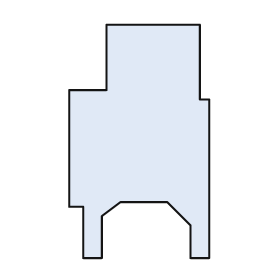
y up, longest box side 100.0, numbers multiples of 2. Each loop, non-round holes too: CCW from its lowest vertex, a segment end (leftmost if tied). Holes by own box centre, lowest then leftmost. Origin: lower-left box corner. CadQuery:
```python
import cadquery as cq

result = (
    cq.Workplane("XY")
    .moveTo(6.0, 0.0)
    .lineTo(14.0, 0.0)
    .lineTo(14.0, 18.0)
    .lineTo(22.0, 24.0)
    .lineTo(42.0, 24.0)
    .lineTo(52.0, 14.0)
    .lineTo(52.0, 0.0)
    .lineTo(60.0, 0.0)
    .lineTo(60.0, 68.0)
    .lineTo(56.0, 68.0)
    .lineTo(56.0, 100.0)
    .lineTo(16.0, 100.0)
    .lineTo(16.0, 72.0)
    .lineTo(0.0, 72.0)
    .lineTo(0.0, 22.0)
    .lineTo(6.0, 22.0)
    .close()
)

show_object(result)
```